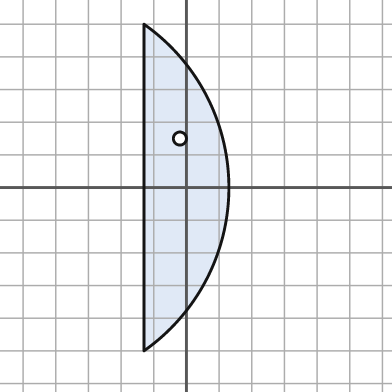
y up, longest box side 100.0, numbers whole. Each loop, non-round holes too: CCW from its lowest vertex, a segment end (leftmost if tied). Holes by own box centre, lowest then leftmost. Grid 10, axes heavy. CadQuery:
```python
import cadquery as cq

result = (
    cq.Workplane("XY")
    .moveTo(-13.0, -50.0)
    .threePointArc((13.0, 0.0), (-13.0, 50.0))
    .close()
    .moveTo(-2.0, 15.0)
    .circle(2.0)
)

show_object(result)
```